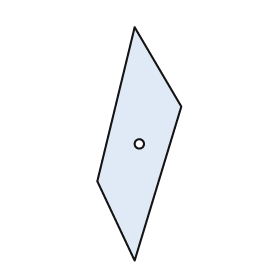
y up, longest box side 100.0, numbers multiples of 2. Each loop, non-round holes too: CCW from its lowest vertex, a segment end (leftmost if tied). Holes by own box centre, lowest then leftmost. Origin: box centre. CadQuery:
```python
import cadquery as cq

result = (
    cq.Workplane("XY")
    .moveTo(-2.0, -50.0)
    .lineTo(18.0, 16.0)
    .lineTo(-2.0, 50.0)
    .lineTo(-18.0, -16.0)
    .close()
    .moveTo(0.0, 0.0)
    .circle(2.0)
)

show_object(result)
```